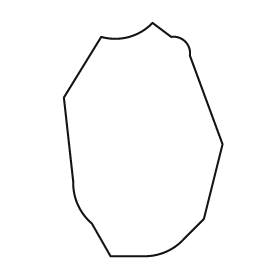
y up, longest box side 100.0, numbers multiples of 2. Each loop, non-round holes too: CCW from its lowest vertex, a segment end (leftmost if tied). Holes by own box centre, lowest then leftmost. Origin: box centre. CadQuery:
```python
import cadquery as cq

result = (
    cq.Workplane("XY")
    .moveTo(-14.0, -50.0)
    .lineTo(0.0, -50.0)
    .threePointArc((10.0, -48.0), (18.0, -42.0))
    .lineTo(26.0, -34.0)
    .lineTo(34.0, -2.0)
    .lineTo(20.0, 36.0)
    .threePointArc((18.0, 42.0), (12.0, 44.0))
    .lineTo(4.0, 50.0)
    .threePointArc((-6.0, 44.0), (-18.0, 44.0))
    .lineTo(-34.0, 18.0)
    .lineTo(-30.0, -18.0)
    .threePointArc((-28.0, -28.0), (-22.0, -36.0))
    .close()
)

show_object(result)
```